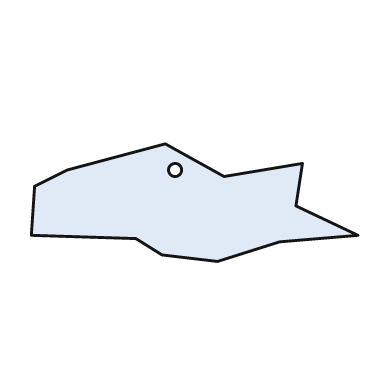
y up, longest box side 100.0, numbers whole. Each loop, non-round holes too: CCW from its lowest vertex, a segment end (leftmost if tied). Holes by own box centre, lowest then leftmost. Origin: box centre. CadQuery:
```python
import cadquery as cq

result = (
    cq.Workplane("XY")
    .moveTo(7.0, -18.0)
    .lineTo(26.0, -12.0)
    .lineTo(50.0, -10.0)
    .lineTo(31.0, -1.0)
    .lineTo(33.0, 12.0)
    .lineTo(9.0, 8.0)
    .lineTo(-9.0, 18.0)
    .lineTo(-39.0, 10.0)
    .lineTo(-49.0, 5.0)
    .lineTo(-50.0, -10.0)
    .lineTo(-18.0, -11.0)
    .lineTo(-10.0, -16.0)
    .close()
    .moveTo(-6.0, 10.0)
    .circle(2.0)
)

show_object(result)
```